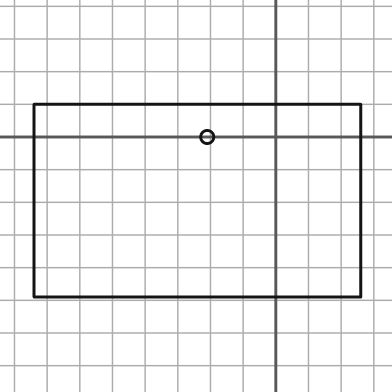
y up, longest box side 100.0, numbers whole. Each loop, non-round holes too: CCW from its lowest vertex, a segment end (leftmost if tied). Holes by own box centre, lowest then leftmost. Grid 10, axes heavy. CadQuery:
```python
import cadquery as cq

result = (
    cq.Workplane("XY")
    .moveTo(-74.0, -49.0)
    .lineTo(26.0, -49.0)
    .lineTo(26.0, 10.0)
    .lineTo(-74.0, 10.0)
    .close()
    .moveTo(-21.0, 0.0)
    .circle(2.0)
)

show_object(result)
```